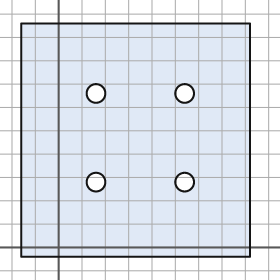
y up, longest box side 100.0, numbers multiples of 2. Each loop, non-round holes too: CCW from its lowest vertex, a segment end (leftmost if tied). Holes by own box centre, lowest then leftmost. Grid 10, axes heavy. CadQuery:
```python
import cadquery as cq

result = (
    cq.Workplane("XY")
    .moveTo(-16.0, -4.0)
    .lineTo(82.0, -4.0)
    .lineTo(82.0, 96.0)
    .lineTo(-16.0, 96.0)
    .close()
    .moveTo(16.0, 28.0)
    .circle(4.0)
    .moveTo(54.0, 28.0)
    .circle(4.0)
    .moveTo(16.0, 66.0)
    .circle(4.0)
    .moveTo(54.0, 66.0)
    .circle(4.0)
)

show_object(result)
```